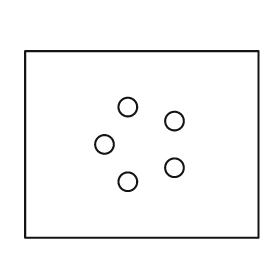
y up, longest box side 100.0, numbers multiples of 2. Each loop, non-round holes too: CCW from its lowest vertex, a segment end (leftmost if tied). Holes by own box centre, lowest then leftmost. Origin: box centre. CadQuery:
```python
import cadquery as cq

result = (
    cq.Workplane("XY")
    .moveTo(-50.0, -40.0)
    .lineTo(50.0, -40.0)
    .lineTo(50.0, 40.0)
    .lineTo(-50.0, 40.0)
    .close()
    .moveTo(-6.0, -16.0)
    .circle(4.0)
    .moveTo(14.0, -10.0)
    .circle(4.0)
    .moveTo(-16.0, 0.0)
    .circle(4.0)
    .moveTo(14.0, 10.0)
    .circle(4.0)
    .moveTo(-6.0, 16.0)
    .circle(4.0)
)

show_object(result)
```